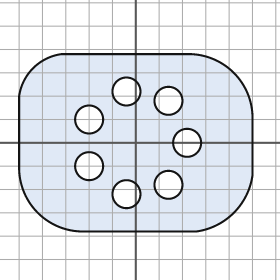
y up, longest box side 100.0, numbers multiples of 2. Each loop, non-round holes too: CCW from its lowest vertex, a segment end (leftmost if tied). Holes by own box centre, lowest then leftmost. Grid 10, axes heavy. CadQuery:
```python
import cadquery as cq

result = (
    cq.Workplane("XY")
    .moveTo(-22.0, -38.0)
    .lineTo(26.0, -38.0)
    .threePointArc((42.0, -30.0), (50.0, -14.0))
    .lineTo(50.0, 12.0)
    .threePointArc((42.0, 30.0), (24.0, 38.0))
    .lineTo(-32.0, 38.0)
    .threePointArc((-44.0, 32.0), (-50.0, 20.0))
    .lineTo(-50.0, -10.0)
    .threePointArc((-42.0, -30.0), (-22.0, -38.0))
    .close()
    .moveTo(-4.0, -22.0)
    .circle(6.0)
    .moveTo(14.0, -18.0)
    .circle(6.0)
    .moveTo(-20.0, -10.0)
    .circle(6.0)
    .moveTo(22.0, 0.0)
    .circle(6.0)
    .moveTo(-20.0, 10.0)
    .circle(6.0)
    .moveTo(14.0, 18.0)
    .circle(6.0)
    .moveTo(-4.0, 22.0)
    .circle(6.0)
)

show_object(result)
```